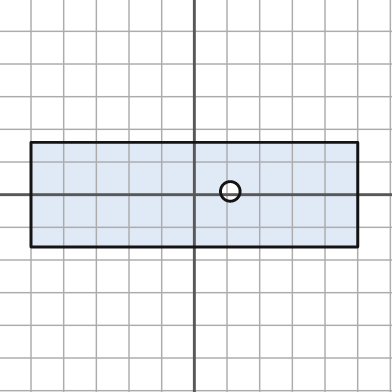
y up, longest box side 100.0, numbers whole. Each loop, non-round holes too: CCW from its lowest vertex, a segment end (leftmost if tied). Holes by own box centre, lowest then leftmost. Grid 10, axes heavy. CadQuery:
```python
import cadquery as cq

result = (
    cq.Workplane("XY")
    .moveTo(-50.0, -16.0)
    .lineTo(50.0, -16.0)
    .lineTo(50.0, 16.0)
    .lineTo(-50.0, 16.0)
    .close()
    .moveTo(11.0, 1.0)
    .circle(3.0)
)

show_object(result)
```